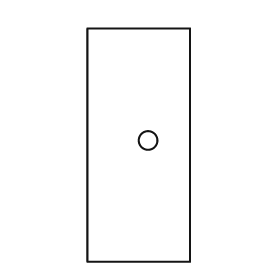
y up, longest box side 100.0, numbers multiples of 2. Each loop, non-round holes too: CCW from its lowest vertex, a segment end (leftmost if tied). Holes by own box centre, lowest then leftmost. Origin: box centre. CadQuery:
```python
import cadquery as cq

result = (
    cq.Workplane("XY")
    .moveTo(-22.0, -50.0)
    .lineTo(22.0, -50.0)
    .lineTo(22.0, 50.0)
    .lineTo(-22.0, 50.0)
    .close()
    .moveTo(4.0, 2.0)
    .circle(4.0)
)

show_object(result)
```